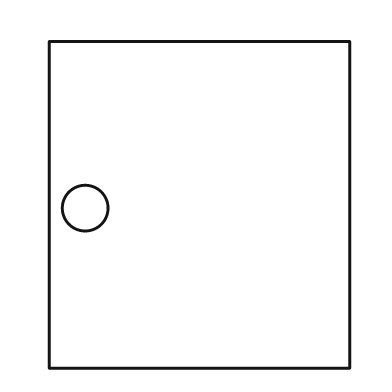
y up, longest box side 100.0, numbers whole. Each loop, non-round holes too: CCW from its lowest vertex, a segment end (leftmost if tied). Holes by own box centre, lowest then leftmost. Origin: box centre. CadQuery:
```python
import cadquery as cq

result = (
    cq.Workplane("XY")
    .moveTo(-46.0, -50.0)
    .lineTo(46.0, -50.0)
    .lineTo(46.0, 50.0)
    .lineTo(-46.0, 50.0)
    .close()
    .moveTo(-35.0, -1.0)
    .circle(7.0)
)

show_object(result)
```